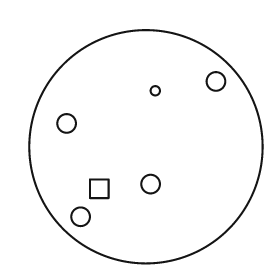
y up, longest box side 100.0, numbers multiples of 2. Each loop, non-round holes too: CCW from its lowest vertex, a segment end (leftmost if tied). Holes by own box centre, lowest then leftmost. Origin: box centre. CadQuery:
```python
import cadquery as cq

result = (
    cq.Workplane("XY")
    .moveTo(0.0, 0.0)
    .circle(50.0)
    .moveTo(-28.0, -30.0)
    .circle(4.0)
    .moveTo(-24.0, -22.0)
    .lineTo(-16.0, -22.0)
    .lineTo(-16.0, -14.0)
    .lineTo(-24.0, -14.0)
    .close()
    .moveTo(2.0, -16.0)
    .circle(4.0)
    .moveTo(-34.0, 10.0)
    .circle(4.0)
    .moveTo(4.0, 24.0)
    .circle(2.0)
    .moveTo(30.0, 28.0)
    .circle(4.0)
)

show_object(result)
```